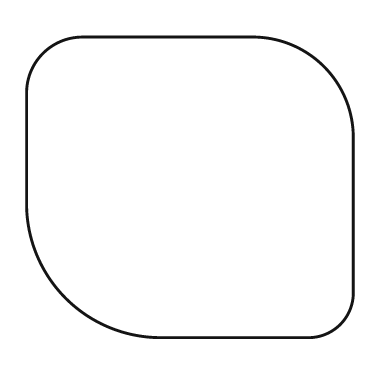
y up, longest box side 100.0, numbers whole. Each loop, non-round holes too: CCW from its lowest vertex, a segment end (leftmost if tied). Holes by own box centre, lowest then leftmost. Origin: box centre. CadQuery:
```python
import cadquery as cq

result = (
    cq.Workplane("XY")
    .moveTo(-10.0, -46.0)
    .lineTo(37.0, -46.0)
    .threePointArc((46.0, -42.0), (50.0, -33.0))
    .lineTo(50.0, 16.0)
    .threePointArc((41.0, 37.0), (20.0, 46.0))
    .lineTo(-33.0, 46.0)
    .threePointArc((-45.0, 41.0), (-50.0, 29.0))
    .lineTo(-50.0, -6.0)
    .threePointArc((-38.0, -34.0), (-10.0, -46.0))
    .close()
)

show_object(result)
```